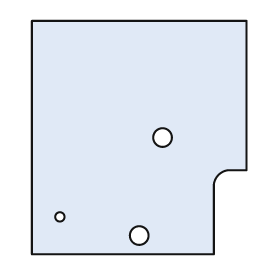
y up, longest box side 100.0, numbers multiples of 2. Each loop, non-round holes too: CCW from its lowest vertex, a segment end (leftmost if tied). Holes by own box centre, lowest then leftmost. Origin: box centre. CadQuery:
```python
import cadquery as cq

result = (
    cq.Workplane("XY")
    .moveTo(-46.0, -50.0)
    .lineTo(32.0, -50.0)
    .lineTo(32.0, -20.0)
    .threePointArc((34.0, -16.0), (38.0, -14.0))
    .lineTo(46.0, -14.0)
    .lineTo(46.0, 50.0)
    .lineTo(-46.0, 50.0)
    .close()
    .moveTo(0.0, -42.0)
    .circle(4.0)
    .moveTo(-34.0, -34.0)
    .circle(2.0)
    .moveTo(10.0, 0.0)
    .circle(4.0)
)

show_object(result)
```